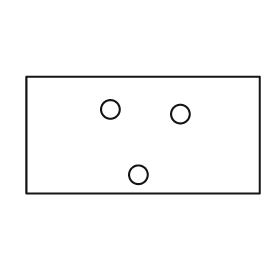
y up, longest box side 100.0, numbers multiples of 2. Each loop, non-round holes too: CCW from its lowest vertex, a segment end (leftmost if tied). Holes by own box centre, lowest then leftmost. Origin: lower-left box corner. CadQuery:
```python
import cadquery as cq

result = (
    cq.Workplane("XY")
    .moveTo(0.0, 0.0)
    .lineTo(100.0, 0.0)
    .lineTo(100.0, 50.0)
    .lineTo(0.0, 50.0)
    .close()
    .moveTo(48.0, 8.0)
    .circle(4.0)
    .moveTo(66.0, 34.0)
    .circle(4.0)
    .moveTo(36.0, 36.0)
    .circle(4.0)
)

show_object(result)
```